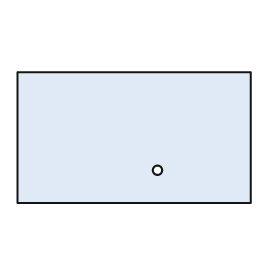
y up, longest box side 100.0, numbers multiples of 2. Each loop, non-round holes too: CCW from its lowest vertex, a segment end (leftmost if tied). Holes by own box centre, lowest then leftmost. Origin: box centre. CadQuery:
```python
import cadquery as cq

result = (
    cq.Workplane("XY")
    .moveTo(-50.0, -28.0)
    .lineTo(50.0, -28.0)
    .lineTo(50.0, 28.0)
    .lineTo(-50.0, 28.0)
    .close()
    .moveTo(10.0, -14.0)
    .circle(2.0)
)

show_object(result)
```